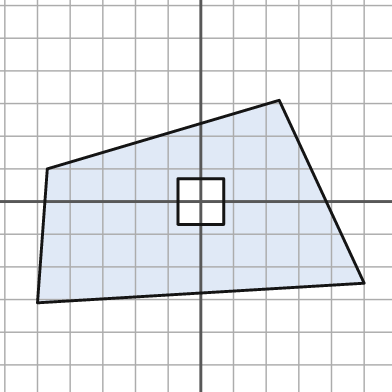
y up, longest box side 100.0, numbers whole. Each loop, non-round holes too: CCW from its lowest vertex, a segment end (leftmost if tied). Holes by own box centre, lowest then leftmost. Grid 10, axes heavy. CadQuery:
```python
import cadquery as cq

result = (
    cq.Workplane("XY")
    .moveTo(-50.0, -31.0)
    .lineTo(50.0, -25.0)
    .lineTo(24.0, 31.0)
    .lineTo(-47.0, 10.0)
    .close()
    .moveTo(-7.0, -7.0)
    .lineTo(7.0, -7.0)
    .lineTo(7.0, 7.0)
    .lineTo(-7.0, 7.0)
    .close()
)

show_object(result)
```